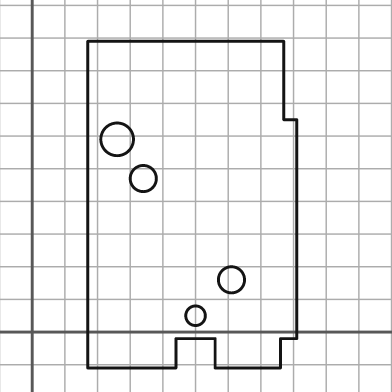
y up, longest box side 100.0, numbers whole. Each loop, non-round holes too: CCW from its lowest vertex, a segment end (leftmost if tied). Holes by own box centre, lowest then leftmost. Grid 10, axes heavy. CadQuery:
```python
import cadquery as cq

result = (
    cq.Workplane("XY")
    .moveTo(17.0, -11.0)
    .lineTo(44.0, -11.0)
    .lineTo(44.0, -2.0)
    .lineTo(56.0, -2.0)
    .lineTo(56.0, -11.0)
    .lineTo(76.0, -11.0)
    .lineTo(76.0, -2.0)
    .lineTo(81.0, -2.0)
    .lineTo(81.0, 65.0)
    .lineTo(77.0, 65.0)
    .lineTo(77.0, 89.0)
    .lineTo(17.0, 89.0)
    .close()
    .moveTo(50.0, 5.0)
    .circle(3.0)
    .moveTo(61.0, 16.0)
    .circle(4.0)
    .moveTo(34.0, 47.0)
    .circle(4.0)
    .moveTo(26.0, 59.0)
    .circle(5.0)
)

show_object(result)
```